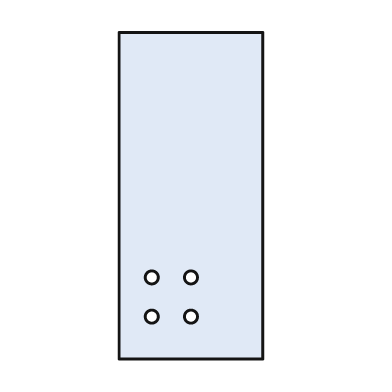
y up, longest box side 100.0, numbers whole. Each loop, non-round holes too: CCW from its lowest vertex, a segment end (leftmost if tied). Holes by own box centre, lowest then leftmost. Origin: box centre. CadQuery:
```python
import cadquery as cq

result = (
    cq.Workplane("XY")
    .moveTo(-22.0, -50.0)
    .lineTo(22.0, -50.0)
    .lineTo(22.0, 50.0)
    .lineTo(-22.0, 50.0)
    .close()
    .moveTo(-12.0, -37.0)
    .circle(2.0)
    .moveTo(0.0, -37.0)
    .circle(2.0)
    .moveTo(-12.0, -25.0)
    .circle(2.0)
    .moveTo(0.0, -25.0)
    .circle(2.0)
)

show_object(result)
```